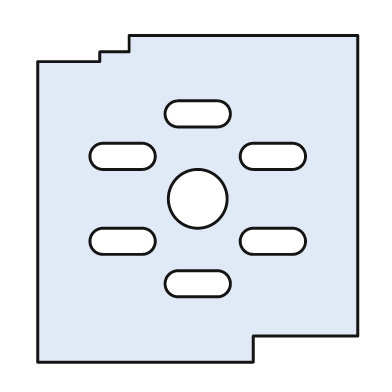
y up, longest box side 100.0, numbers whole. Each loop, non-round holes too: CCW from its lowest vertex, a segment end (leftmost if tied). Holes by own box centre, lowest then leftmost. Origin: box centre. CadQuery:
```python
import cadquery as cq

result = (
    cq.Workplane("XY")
    .moveTo(-49.0, -50.0)
    .lineTo(17.0, -50.0)
    .lineTo(17.0, -42.0)
    .lineTo(49.0, -42.0)
    .lineTo(49.0, 50.0)
    .lineTo(-21.0, 50.0)
    .lineTo(-21.0, 45.0)
    .lineTo(-30.0, 45.0)
    .lineTo(-30.0, 42.0)
    .lineTo(-49.0, 42.0)
    .close()
    .moveTo(-6.0, -30.0)
    .lineTo(6.0, -30.0)
    .threePointArc((10.0, -26.0), (6.0, -22.0))
    .lineTo(-6.0, -22.0)
    .threePointArc((-10.0, -26.0), (-6.0, -30.0))
    .close()
    .moveTo(-29.0, -17.0)
    .lineTo(-17.0, -17.0)
    .threePointArc((-13.0, -13.0), (-17.0, -9.0))
    .lineTo(-29.0, -9.0)
    .threePointArc((-33.0, -13.0), (-29.0, -17.0))
    .close()
    .moveTo(17.0, -17.0)
    .lineTo(29.0, -17.0)
    .threePointArc((33.0, -13.0), (29.0, -9.0))
    .lineTo(17.0, -9.0)
    .threePointArc((13.0, -13.0), (17.0, -17.0))
    .close()
    .moveTo(0.0, 0.0)
    .circle(9.0)
    .moveTo(-29.0, 9.0)
    .lineTo(-17.0, 9.0)
    .threePointArc((-13.0, 13.0), (-17.0, 17.0))
    .lineTo(-29.0, 17.0)
    .threePointArc((-33.0, 13.0), (-29.0, 9.0))
    .close()
    .moveTo(17.0, 9.0)
    .lineTo(29.0, 9.0)
    .threePointArc((33.0, 13.0), (29.0, 17.0))
    .lineTo(17.0, 17.0)
    .threePointArc((13.0, 13.0), (17.0, 9.0))
    .close()
    .moveTo(-6.0, 22.0)
    .lineTo(6.0, 22.0)
    .threePointArc((10.0, 26.0), (6.0, 30.0))
    .lineTo(-6.0, 30.0)
    .threePointArc((-10.0, 26.0), (-6.0, 22.0))
    .close()
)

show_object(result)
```